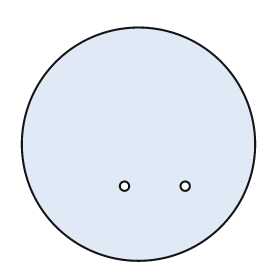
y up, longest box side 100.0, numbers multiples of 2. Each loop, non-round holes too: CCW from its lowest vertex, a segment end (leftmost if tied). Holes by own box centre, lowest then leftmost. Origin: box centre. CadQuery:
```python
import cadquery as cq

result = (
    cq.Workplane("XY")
    .moveTo(0.0, 0.0)
    .circle(50.0)
    .moveTo(-6.0, -18.0)
    .circle(2.0)
    .moveTo(20.0, -18.0)
    .circle(2.0)
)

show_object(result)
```